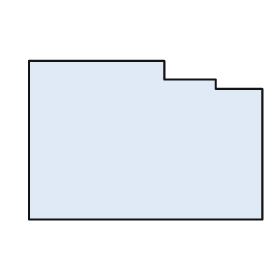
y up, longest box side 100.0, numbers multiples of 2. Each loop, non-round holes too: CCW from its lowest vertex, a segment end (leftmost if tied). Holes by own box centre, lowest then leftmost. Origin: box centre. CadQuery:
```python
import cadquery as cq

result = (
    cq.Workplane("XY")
    .moveTo(-50.0, -34.0)
    .lineTo(50.0, -34.0)
    .lineTo(50.0, 22.0)
    .lineTo(30.0, 22.0)
    .lineTo(30.0, 26.0)
    .lineTo(8.0, 26.0)
    .lineTo(8.0, 34.0)
    .lineTo(-50.0, 34.0)
    .close()
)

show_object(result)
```